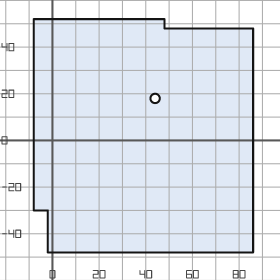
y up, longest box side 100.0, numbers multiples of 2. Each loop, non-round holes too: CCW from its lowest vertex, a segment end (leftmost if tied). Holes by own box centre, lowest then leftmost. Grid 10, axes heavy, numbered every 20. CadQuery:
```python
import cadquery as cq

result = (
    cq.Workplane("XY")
    .moveTo(-2.0, -48.0)
    .lineTo(86.0, -48.0)
    .lineTo(86.0, 48.0)
    .lineTo(48.0, 48.0)
    .lineTo(48.0, 52.0)
    .lineTo(-8.0, 52.0)
    .lineTo(-8.0, -30.0)
    .lineTo(-2.0, -30.0)
    .close()
    .moveTo(44.0, 18.0)
    .circle(2.0)
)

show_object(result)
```